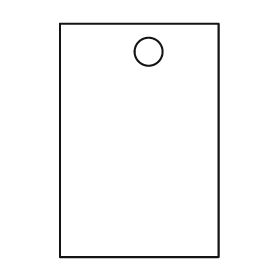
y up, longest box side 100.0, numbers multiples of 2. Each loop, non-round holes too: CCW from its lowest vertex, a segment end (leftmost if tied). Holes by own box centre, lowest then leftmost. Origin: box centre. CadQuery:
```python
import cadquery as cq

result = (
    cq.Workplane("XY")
    .moveTo(-34.0, -50.0)
    .lineTo(34.0, -50.0)
    .lineTo(34.0, 50.0)
    .lineTo(-34.0, 50.0)
    .close()
    .moveTo(4.0, 38.0)
    .circle(6.0)
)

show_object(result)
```